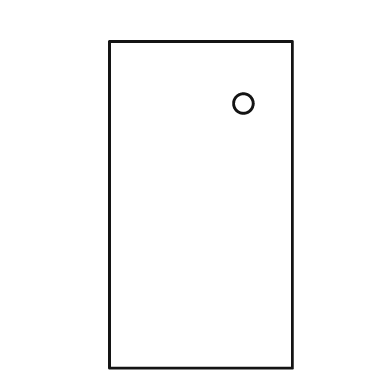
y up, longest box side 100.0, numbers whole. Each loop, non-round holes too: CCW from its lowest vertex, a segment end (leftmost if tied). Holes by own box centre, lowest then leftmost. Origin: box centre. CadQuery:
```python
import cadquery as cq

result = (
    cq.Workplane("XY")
    .moveTo(-28.0, -50.0)
    .lineTo(28.0, -50.0)
    .lineTo(28.0, 50.0)
    .lineTo(-28.0, 50.0)
    .close()
    .moveTo(13.0, 31.0)
    .circle(3.0)
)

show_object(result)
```